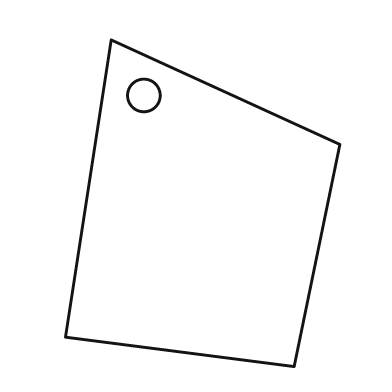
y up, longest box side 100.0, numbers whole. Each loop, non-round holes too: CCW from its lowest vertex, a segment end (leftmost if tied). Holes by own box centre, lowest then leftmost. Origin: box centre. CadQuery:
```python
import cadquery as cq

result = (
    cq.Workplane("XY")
    .moveTo(28.0, -50.0)
    .lineTo(42.0, 18.0)
    .lineTo(-28.0, 50.0)
    .lineTo(-42.0, -41.0)
    .close()
    .moveTo(-18.0, 33.0)
    .circle(5.0)
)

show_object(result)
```